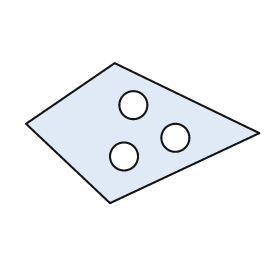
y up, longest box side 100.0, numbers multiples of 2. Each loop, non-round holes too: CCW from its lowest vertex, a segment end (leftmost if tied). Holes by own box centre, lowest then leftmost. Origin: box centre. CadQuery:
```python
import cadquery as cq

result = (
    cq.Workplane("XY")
    .moveTo(-14.0, -30.0)
    .lineTo(50.0, 0.0)
    .lineTo(-12.0, 30.0)
    .lineTo(-50.0, 4.0)
    .close()
    .moveTo(-8.0, -10.0)
    .circle(6.0)
    .moveTo(14.0, -2.0)
    .circle(6.0)
    .moveTo(-4.0, 12.0)
    .circle(6.0)
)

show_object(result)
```